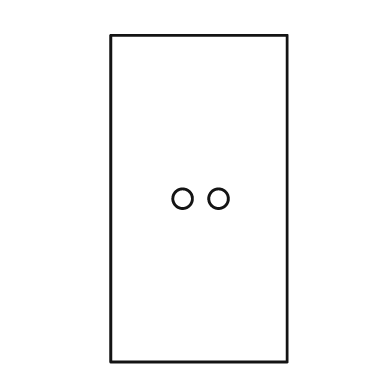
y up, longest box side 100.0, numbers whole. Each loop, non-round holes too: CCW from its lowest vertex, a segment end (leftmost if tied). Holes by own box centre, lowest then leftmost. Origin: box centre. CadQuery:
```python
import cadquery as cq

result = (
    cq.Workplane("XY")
    .moveTo(-27.0, -50.0)
    .lineTo(27.0, -50.0)
    .lineTo(27.0, 50.0)
    .lineTo(-27.0, 50.0)
    .close()
    .moveTo(-5.0, 0.0)
    .circle(3.0)
    .moveTo(6.0, 0.0)
    .circle(3.0)
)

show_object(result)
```